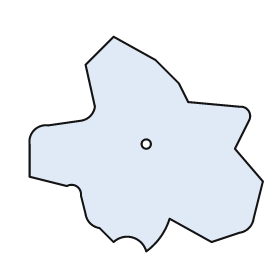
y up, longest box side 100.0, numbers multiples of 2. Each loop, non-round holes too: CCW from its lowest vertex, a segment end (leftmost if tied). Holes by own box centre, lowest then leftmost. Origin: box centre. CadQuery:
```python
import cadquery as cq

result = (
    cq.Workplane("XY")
    .moveTo(0.0, -46.0)
    .threePointArc((6.0, -40.0), (10.0, -32.0))
    .lineTo(28.0, -42.0)
    .lineTo(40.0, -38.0)
    .threePointArc((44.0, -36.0), (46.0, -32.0))
    .lineTo(50.0, -16.0)
    .lineTo(38.0, -2.0)
    .lineTo(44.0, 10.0)
    .threePointArc((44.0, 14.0), (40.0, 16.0))
    .lineTo(18.0, 18.0)
    .lineTo(14.0, 26.0)
    .lineTo(4.0, 36.0)
    .lineTo(-14.0, 46.0)
    .lineTo(-26.0, 34.0)
    .lineTo(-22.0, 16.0)
    .threePointArc((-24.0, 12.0), (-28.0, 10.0))
    .lineTo(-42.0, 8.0)
    .threePointArc((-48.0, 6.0), (-50.0, 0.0))
    .lineTo(-50.0, -14.0)
    .lineTo(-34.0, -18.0)
    .threePointArc((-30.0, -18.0), (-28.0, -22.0))
    .lineTo(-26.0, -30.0)
    .threePointArc((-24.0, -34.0), (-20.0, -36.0))
    .lineTo(-14.0, -42.0)
    .threePointArc((-6.0, -40.0), (0.0, -46.0))
    .close()
    .moveTo(0.0, 0.0)
    .circle(2.0)
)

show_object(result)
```